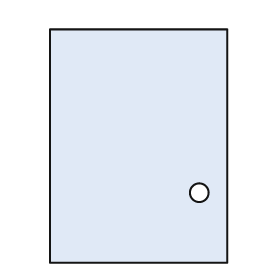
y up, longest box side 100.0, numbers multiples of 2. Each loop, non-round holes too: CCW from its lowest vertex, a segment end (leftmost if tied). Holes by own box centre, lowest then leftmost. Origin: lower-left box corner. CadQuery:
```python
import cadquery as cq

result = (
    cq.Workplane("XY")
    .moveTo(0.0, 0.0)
    .lineTo(76.0, 0.0)
    .lineTo(76.0, 100.0)
    .lineTo(0.0, 100.0)
    .close()
    .moveTo(64.0, 30.0)
    .circle(4.0)
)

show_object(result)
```